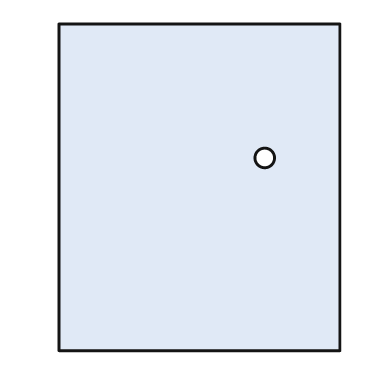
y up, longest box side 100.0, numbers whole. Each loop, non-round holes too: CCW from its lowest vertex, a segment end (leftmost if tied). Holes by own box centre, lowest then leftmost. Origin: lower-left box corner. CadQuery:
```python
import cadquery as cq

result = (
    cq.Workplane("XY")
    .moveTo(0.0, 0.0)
    .lineTo(86.0, 0.0)
    .lineTo(86.0, 100.0)
    .lineTo(0.0, 100.0)
    .close()
    .moveTo(63.0, 59.0)
    .circle(3.0)
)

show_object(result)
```